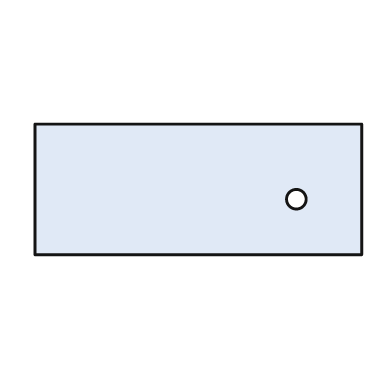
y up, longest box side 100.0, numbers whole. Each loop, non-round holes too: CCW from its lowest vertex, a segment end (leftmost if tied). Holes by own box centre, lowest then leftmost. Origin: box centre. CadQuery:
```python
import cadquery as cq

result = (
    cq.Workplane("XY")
    .moveTo(-50.0, -20.0)
    .lineTo(50.0, -20.0)
    .lineTo(50.0, 20.0)
    .lineTo(-50.0, 20.0)
    .close()
    .moveTo(30.0, -3.0)
    .circle(3.0)
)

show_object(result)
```